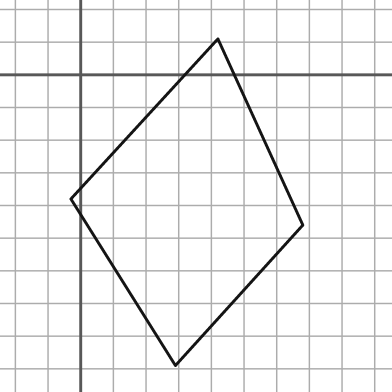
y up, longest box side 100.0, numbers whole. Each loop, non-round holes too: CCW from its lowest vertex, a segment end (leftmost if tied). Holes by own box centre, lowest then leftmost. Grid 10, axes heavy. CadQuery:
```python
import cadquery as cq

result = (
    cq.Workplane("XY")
    .moveTo(29.0, -89.0)
    .lineTo(68.0, -46.0)
    .lineTo(42.0, 11.0)
    .lineTo(-3.0, -38.0)
    .close()
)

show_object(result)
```